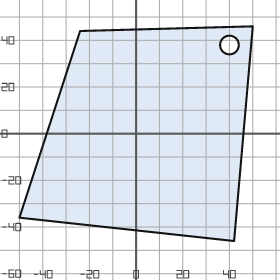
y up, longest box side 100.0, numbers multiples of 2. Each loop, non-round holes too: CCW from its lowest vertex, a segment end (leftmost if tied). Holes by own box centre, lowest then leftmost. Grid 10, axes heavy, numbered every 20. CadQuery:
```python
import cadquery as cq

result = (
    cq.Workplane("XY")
    .moveTo(42.0, -46.0)
    .lineTo(50.0, 46.0)
    .lineTo(-24.0, 44.0)
    .lineTo(-50.0, -36.0)
    .close()
    .moveTo(40.0, 38.0)
    .circle(4.0)
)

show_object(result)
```